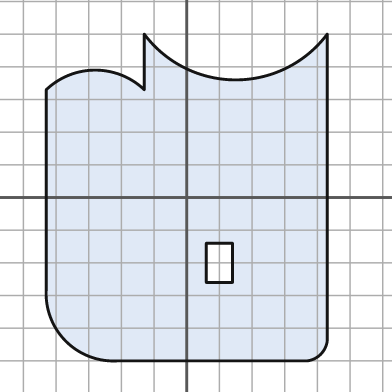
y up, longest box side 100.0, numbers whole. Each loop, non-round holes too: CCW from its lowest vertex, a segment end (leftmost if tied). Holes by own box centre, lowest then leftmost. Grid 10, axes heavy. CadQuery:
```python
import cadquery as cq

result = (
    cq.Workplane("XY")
    .moveTo(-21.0, -50.0)
    .lineTo(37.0, -50.0)
    .threePointArc((41.0, -48.0), (43.0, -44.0))
    .lineTo(43.0, 50.0)
    .threePointArc((15.0, 36.0), (-13.0, 50.0))
    .lineTo(-13.0, 33.0)
    .threePointArc((-28.0, 39.0), (-43.0, 33.0))
    .lineTo(-43.0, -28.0)
    .threePointArc((-37.0, -44.0), (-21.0, -50.0))
    .close()
    .moveTo(6.0, -26.0)
    .lineTo(14.0, -26.0)
    .lineTo(14.0, -14.0)
    .lineTo(6.0, -14.0)
    .close()
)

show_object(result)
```